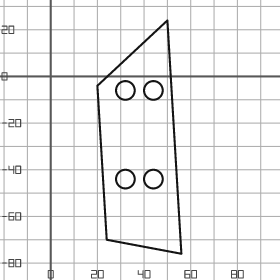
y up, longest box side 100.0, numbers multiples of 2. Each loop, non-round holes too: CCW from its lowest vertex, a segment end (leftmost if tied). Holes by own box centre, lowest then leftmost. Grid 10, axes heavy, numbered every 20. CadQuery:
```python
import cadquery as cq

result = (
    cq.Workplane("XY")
    .moveTo(56.0, -76.0)
    .lineTo(50.0, 24.0)
    .lineTo(20.0, -4.0)
    .lineTo(24.0, -70.0)
    .close()
    .moveTo(32.0, -44.0)
    .circle(4.0)
    .moveTo(44.0, -44.0)
    .circle(4.0)
    .moveTo(32.0, -6.0)
    .circle(4.0)
    .moveTo(44.0, -6.0)
    .circle(4.0)
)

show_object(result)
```